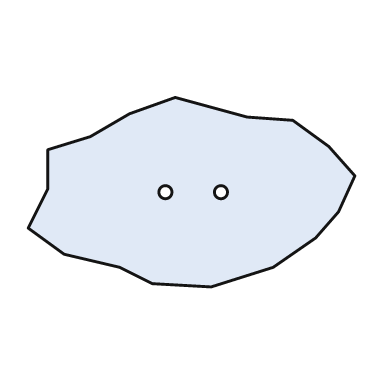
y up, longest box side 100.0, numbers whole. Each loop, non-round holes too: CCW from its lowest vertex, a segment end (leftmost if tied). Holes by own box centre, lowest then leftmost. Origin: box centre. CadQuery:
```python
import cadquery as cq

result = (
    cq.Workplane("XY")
    .moveTo(6.0, -29.0)
    .lineTo(25.0, -23.0)
    .lineTo(38.0, -14.0)
    .lineTo(45.0, -6.0)
    .lineTo(50.0, 5.0)
    .lineTo(42.0, 14.0)
    .lineTo(31.0, 22.0)
    .lineTo(17.0, 23.0)
    .lineTo(-5.0, 29.0)
    .lineTo(-19.0, 24.0)
    .lineTo(-31.0, 17.0)
    .lineTo(-44.0, 13.0)
    .lineTo(-44.0, 1.0)
    .lineTo(-50.0, -11.0)
    .lineTo(-39.0, -19.0)
    .lineTo(-22.0, -23.0)
    .lineTo(-12.0, -28.0)
    .close()
    .moveTo(-8.0, 0.0)
    .circle(2.0)
    .moveTo(9.0, 0.0)
    .circle(2.0)
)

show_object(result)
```